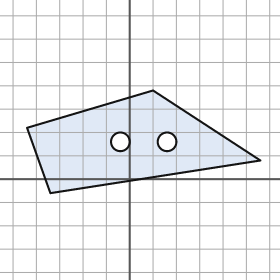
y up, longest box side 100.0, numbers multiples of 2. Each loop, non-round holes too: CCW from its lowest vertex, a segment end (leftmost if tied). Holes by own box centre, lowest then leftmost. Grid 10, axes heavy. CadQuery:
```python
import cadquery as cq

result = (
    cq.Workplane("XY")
    .moveTo(-34.0, -6.0)
    .lineTo(56.0, 8.0)
    .lineTo(10.0, 38.0)
    .lineTo(-44.0, 22.0)
    .close()
    .moveTo(-4.0, 16.0)
    .circle(4.0)
    .moveTo(16.0, 16.0)
    .circle(4.0)
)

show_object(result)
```